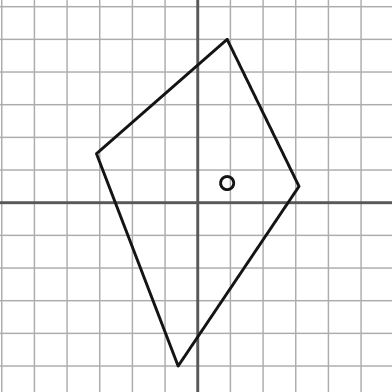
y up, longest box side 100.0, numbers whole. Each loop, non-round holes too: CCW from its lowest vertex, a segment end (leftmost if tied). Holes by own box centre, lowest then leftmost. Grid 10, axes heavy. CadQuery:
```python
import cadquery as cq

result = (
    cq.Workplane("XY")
    .moveTo(-6.0, -50.0)
    .lineTo(31.0, 5.0)
    .lineTo(9.0, 50.0)
    .lineTo(-31.0, 15.0)
    .close()
    .moveTo(9.0, 6.0)
    .circle(2.0)
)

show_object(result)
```